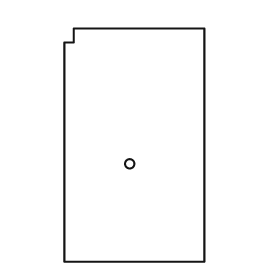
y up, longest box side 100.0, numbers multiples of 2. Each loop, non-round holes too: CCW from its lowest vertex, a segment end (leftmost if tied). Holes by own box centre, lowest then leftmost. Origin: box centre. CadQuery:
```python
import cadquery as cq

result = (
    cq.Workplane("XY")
    .moveTo(-30.0, -50.0)
    .lineTo(30.0, -50.0)
    .lineTo(30.0, 50.0)
    .lineTo(-26.0, 50.0)
    .lineTo(-26.0, 44.0)
    .lineTo(-30.0, 44.0)
    .close()
    .moveTo(-2.0, -8.0)
    .circle(2.0)
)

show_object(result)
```